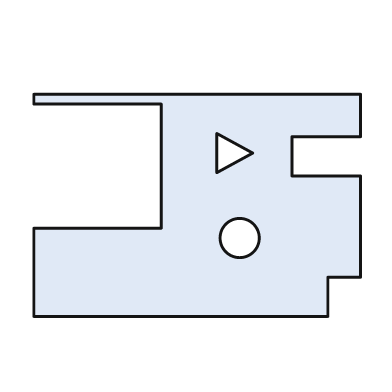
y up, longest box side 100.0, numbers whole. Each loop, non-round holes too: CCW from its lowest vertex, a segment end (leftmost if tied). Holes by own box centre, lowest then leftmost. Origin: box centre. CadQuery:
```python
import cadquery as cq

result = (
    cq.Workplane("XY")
    .moveTo(-50.0, -34.0)
    .lineTo(40.0, -34.0)
    .lineTo(40.0, -22.0)
    .lineTo(50.0, -22.0)
    .lineTo(50.0, 9.0)
    .lineTo(29.0, 9.0)
    .lineTo(29.0, 21.0)
    .lineTo(50.0, 21.0)
    .lineTo(50.0, 34.0)
    .lineTo(-50.0, 34.0)
    .lineTo(-50.0, 31.0)
    .lineTo(-11.0, 31.0)
    .lineTo(-11.0, -7.0)
    .lineTo(-50.0, -7.0)
    .close()
    .moveTo(13.0, -10.0)
    .circle(6.0)
    .moveTo(6.0, 10.0)
    .lineTo(17.0, 16.0)
    .lineTo(6.0, 22.0)
    .close()
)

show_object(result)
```